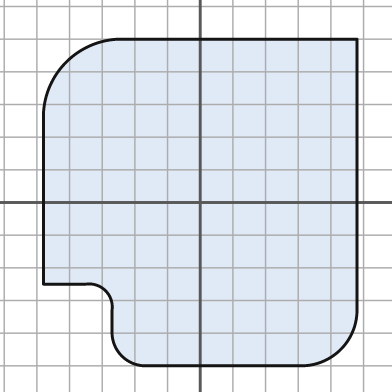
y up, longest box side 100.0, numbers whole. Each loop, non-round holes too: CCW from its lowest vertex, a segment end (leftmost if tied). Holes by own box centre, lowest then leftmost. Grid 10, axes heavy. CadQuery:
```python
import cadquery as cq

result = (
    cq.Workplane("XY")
    .moveTo(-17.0, -50.0)
    .lineTo(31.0, -50.0)
    .threePointArc((43.0, -45.0), (48.0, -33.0))
    .lineTo(48.0, 50.0)
    .lineTo(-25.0, 50.0)
    .threePointArc((-41.0, 43.0), (-48.0, 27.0))
    .lineTo(-48.0, -25.0)
    .lineTo(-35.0, -25.0)
    .threePointArc((-29.0, -27.0), (-27.0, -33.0))
    .lineTo(-27.0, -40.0)
    .threePointArc((-24.0, -47.0), (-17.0, -50.0))
    .close()
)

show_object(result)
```